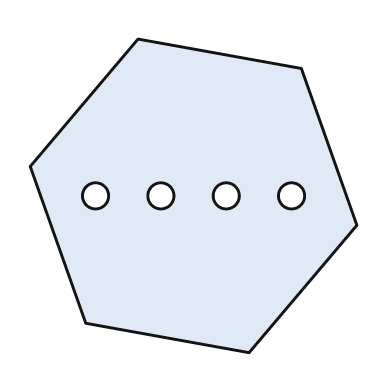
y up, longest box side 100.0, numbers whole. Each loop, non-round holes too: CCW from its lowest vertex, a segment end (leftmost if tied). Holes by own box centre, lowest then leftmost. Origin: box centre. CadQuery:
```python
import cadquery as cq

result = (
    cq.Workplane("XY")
    .moveTo(17.0, -48.0)
    .lineTo(50.0, -9.0)
    .lineTo(33.0, 39.0)
    .lineTo(-17.0, 48.0)
    .lineTo(-50.0, 9.0)
    .lineTo(-33.0, -39.0)
    .close()
    .moveTo(-30.0, 0.0)
    .circle(4.0)
    .moveTo(-10.0, 0.0)
    .circle(4.0)
    .moveTo(10.0, 0.0)
    .circle(4.0)
    .moveTo(30.0, 0.0)
    .circle(4.0)
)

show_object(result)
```